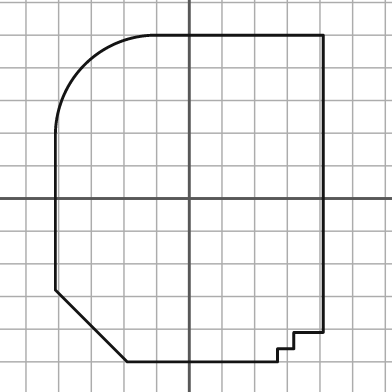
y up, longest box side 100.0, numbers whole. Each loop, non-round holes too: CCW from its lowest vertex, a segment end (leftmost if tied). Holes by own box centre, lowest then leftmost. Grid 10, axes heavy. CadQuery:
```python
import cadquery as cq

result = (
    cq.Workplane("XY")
    .moveTo(-19.0, -50.0)
    .lineTo(27.0, -50.0)
    .lineTo(27.0, -46.0)
    .lineTo(32.0, -46.0)
    .lineTo(32.0, -41.0)
    .lineTo(41.0, -41.0)
    .lineTo(41.0, 50.0)
    .lineTo(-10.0, 50.0)
    .threePointArc((-32.0, 41.0), (-41.0, 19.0))
    .lineTo(-41.0, -28.0)
    .close()
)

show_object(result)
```